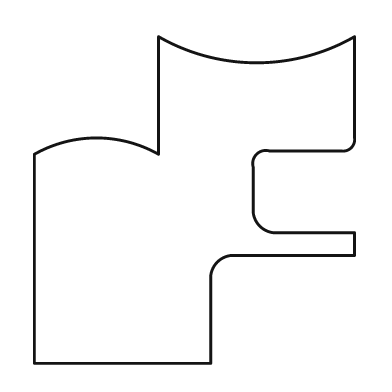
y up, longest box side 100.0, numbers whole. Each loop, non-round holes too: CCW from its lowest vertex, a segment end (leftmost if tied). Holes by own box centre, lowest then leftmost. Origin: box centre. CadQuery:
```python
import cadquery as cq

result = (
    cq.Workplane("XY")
    .moveTo(-49.0, -50.0)
    .lineTo(5.0, -50.0)
    .lineTo(5.0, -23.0)
    .threePointArc((7.0, -19.0), (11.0, -17.0))
    .lineTo(49.0, -17.0)
    .lineTo(49.0, -10.0)
    .lineTo(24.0, -10.0)
    .threePointArc((20.0, -8.0), (18.0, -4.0))
    .lineTo(18.0, 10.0)
    .threePointArc((19.0, 14.0), (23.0, 15.0))
    .lineTo(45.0, 15.0)
    .threePointArc((48.0, 16.0), (49.0, 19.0))
    .lineTo(49.0, 50.0)
    .threePointArc((19.0, 42.0), (-11.0, 50.0))
    .lineTo(-11.0, 14.0)
    .threePointArc((-30.0, 19.0), (-49.0, 14.0))
    .close()
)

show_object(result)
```